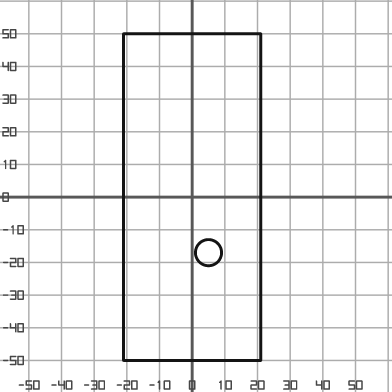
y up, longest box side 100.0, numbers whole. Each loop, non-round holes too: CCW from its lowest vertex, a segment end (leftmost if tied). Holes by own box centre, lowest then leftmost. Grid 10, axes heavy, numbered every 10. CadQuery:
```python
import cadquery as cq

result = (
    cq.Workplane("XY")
    .moveTo(-21.0, -50.0)
    .lineTo(21.0, -50.0)
    .lineTo(21.0, 50.0)
    .lineTo(-21.0, 50.0)
    .close()
    .moveTo(5.0, -17.0)
    .circle(4.0)
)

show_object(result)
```